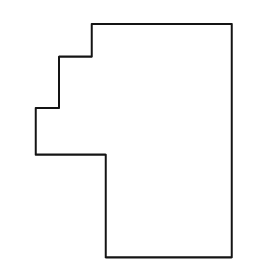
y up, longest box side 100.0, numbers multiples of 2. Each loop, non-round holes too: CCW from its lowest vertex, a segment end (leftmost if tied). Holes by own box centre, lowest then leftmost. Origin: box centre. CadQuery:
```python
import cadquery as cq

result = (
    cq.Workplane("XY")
    .moveTo(-12.0, -50.0)
    .lineTo(42.0, -50.0)
    .lineTo(42.0, 50.0)
    .lineTo(-18.0, 50.0)
    .lineTo(-18.0, 36.0)
    .lineTo(-32.0, 36.0)
    .lineTo(-32.0, 14.0)
    .lineTo(-42.0, 14.0)
    .lineTo(-42.0, -6.0)
    .lineTo(-12.0, -6.0)
    .close()
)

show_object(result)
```